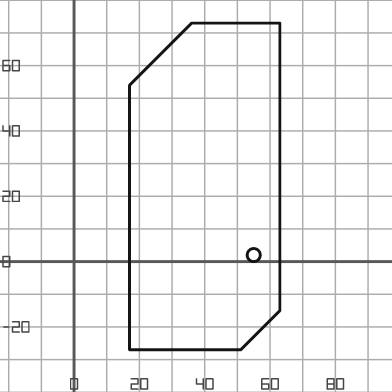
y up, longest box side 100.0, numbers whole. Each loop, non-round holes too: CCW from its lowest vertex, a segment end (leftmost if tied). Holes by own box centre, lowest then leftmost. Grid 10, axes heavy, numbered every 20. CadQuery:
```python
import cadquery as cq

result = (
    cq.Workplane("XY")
    .moveTo(17.0, -27.0)
    .lineTo(51.0, -27.0)
    .lineTo(63.0, -15.0)
    .lineTo(63.0, 73.0)
    .lineTo(36.0, 73.0)
    .lineTo(17.0, 54.0)
    .close()
    .moveTo(55.0, 2.0)
    .circle(2.0)
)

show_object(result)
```